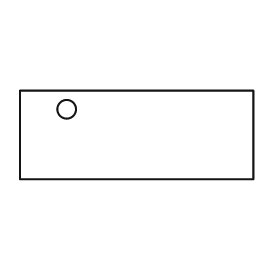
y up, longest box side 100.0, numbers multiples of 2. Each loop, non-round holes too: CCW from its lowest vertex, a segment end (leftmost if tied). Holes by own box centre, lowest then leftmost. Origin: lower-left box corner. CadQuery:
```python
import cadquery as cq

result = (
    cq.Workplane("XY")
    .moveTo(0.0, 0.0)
    .lineTo(100.0, 0.0)
    .lineTo(100.0, 38.0)
    .lineTo(0.0, 38.0)
    .close()
    .moveTo(20.0, 30.0)
    .circle(4.0)
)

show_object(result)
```